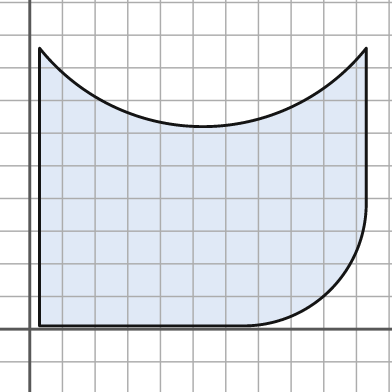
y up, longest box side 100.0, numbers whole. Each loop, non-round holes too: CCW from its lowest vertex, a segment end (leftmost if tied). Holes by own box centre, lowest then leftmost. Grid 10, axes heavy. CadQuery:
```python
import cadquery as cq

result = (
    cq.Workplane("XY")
    .moveTo(3.0, 1.0)
    .lineTo(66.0, 1.0)
    .threePointArc((92.0, 12.0), (103.0, 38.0))
    .lineTo(103.0, 86.0)
    .threePointArc((53.0, 62.0), (3.0, 86.0))
    .close()
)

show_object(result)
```